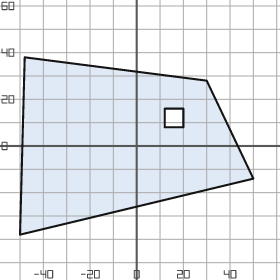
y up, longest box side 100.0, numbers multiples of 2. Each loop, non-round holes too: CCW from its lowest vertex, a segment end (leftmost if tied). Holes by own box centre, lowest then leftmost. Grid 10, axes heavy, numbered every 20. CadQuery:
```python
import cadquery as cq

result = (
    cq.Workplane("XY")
    .moveTo(-50.0, -38.0)
    .lineTo(50.0, -14.0)
    .lineTo(30.0, 28.0)
    .lineTo(-48.0, 38.0)
    .close()
    .moveTo(12.0, 8.0)
    .lineTo(20.0, 8.0)
    .lineTo(20.0, 16.0)
    .lineTo(12.0, 16.0)
    .close()
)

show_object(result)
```